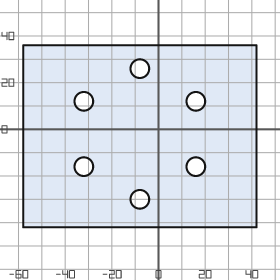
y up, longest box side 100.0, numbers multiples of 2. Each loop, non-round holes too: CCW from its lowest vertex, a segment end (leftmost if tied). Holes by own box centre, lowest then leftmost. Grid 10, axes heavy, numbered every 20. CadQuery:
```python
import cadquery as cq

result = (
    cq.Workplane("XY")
    .moveTo(-58.0, -42.0)
    .lineTo(42.0, -42.0)
    .lineTo(42.0, 36.0)
    .lineTo(-58.0, 36.0)
    .close()
    .moveTo(-8.0, -30.0)
    .circle(4.0)
    .moveTo(-32.0, -16.0)
    .circle(4.0)
    .moveTo(16.0, -16.0)
    .circle(4.0)
    .moveTo(-32.0, 12.0)
    .circle(4.0)
    .moveTo(16.0, 12.0)
    .circle(4.0)
    .moveTo(-8.0, 26.0)
    .circle(4.0)
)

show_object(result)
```